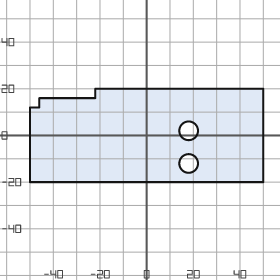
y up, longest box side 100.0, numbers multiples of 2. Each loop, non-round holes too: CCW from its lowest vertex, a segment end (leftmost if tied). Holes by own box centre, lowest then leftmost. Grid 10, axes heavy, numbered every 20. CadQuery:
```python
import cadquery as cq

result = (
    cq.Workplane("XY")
    .moveTo(-50.0, -20.0)
    .lineTo(50.0, -20.0)
    .lineTo(50.0, 20.0)
    .lineTo(-22.0, 20.0)
    .lineTo(-22.0, 16.0)
    .lineTo(-46.0, 16.0)
    .lineTo(-46.0, 12.0)
    .lineTo(-50.0, 12.0)
    .close()
    .moveTo(18.0, -12.0)
    .circle(4.0)
    .moveTo(18.0, 2.0)
    .circle(4.0)
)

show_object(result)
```